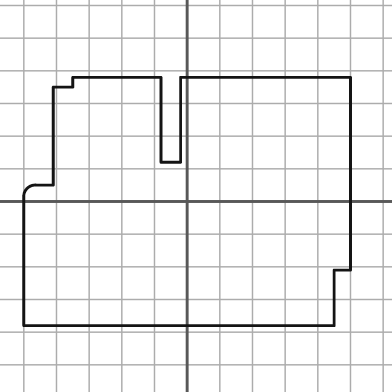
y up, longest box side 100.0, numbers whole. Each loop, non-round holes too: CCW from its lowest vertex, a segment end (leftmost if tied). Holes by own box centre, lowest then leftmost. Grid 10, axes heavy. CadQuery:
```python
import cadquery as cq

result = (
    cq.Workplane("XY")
    .moveTo(-50.0, -38.0)
    .lineTo(45.0, -38.0)
    .lineTo(45.0, -21.0)
    .lineTo(50.0, -21.0)
    .lineTo(50.0, 38.0)
    .lineTo(-2.0, 38.0)
    .lineTo(-2.0, 12.0)
    .lineTo(-8.0, 12.0)
    .lineTo(-8.0, 38.0)
    .lineTo(-35.0, 38.0)
    .lineTo(-35.0, 35.0)
    .lineTo(-41.0, 35.0)
    .lineTo(-41.0, 5.0)
    .lineTo(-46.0, 5.0)
    .threePointArc((-49.0, 4.0), (-50.0, 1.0))
    .close()
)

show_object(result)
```